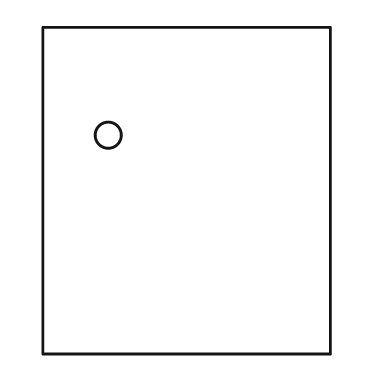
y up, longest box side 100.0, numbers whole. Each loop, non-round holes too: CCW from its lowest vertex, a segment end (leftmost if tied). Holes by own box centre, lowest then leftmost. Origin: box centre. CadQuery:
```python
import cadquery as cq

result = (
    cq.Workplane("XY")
    .moveTo(-44.0, -50.0)
    .lineTo(44.0, -50.0)
    .lineTo(44.0, 50.0)
    .lineTo(-44.0, 50.0)
    .close()
    .moveTo(-24.0, 17.0)
    .circle(4.0)
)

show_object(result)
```